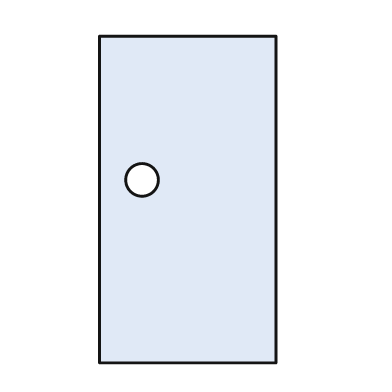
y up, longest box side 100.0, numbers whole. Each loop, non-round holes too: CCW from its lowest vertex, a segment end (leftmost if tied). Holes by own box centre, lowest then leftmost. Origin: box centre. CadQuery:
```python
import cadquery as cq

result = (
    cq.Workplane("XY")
    .moveTo(-27.0, -50.0)
    .lineTo(27.0, -50.0)
    .lineTo(27.0, 50.0)
    .lineTo(-27.0, 50.0)
    .close()
    .moveTo(-14.0, 6.0)
    .circle(5.0)
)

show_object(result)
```